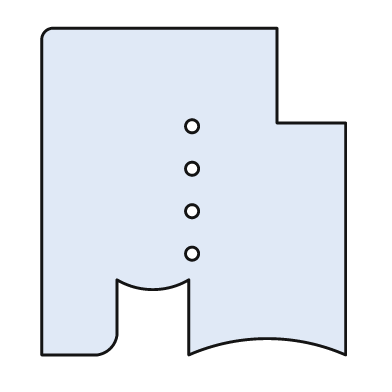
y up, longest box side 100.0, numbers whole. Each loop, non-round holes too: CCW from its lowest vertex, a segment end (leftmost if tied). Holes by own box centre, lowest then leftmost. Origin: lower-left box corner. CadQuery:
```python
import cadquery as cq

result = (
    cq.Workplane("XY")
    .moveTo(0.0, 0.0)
    .lineTo(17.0, 0.0)
    .threePointArc((21.0, 2.0), (23.0, 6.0))
    .lineTo(23.0, 23.0)
    .threePointArc((34.0, 20.0), (45.0, 23.0))
    .lineTo(45.0, 0.0)
    .threePointArc((69.0, 5.0), (93.0, 0.0))
    .lineTo(93.0, 71.0)
    .lineTo(72.0, 71.0)
    .lineTo(72.0, 100.0)
    .lineTo(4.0, 100.0)
    .threePointArc((1.0, 99.0), (0.0, 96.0))
    .close()
    .moveTo(46.0, 31.0)
    .circle(2.0)
    .moveTo(46.0, 44.0)
    .circle(2.0)
    .moveTo(46.0, 57.0)
    .circle(2.0)
    .moveTo(46.0, 70.0)
    .circle(2.0)
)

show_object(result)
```